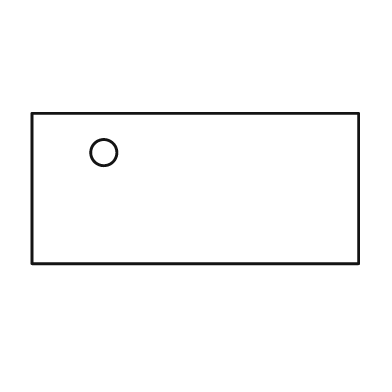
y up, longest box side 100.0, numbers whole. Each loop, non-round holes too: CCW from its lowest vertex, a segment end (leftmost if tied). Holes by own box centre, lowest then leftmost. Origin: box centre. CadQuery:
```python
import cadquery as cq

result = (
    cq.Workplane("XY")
    .moveTo(-50.0, -23.0)
    .lineTo(50.0, -23.0)
    .lineTo(50.0, 23.0)
    .lineTo(-50.0, 23.0)
    .close()
    .moveTo(-28.0, 11.0)
    .circle(4.0)
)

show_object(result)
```